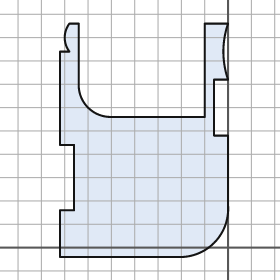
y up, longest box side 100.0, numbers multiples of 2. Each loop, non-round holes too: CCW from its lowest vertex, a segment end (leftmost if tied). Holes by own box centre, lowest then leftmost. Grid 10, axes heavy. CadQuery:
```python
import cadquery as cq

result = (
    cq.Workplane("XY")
    .moveTo(-72.0, -4.0)
    .lineTo(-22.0, -4.0)
    .threePointArc((-6.0, 2.0), (0.0, 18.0))
    .lineTo(0.0, 48.0)
    .lineTo(-6.0, 48.0)
    .lineTo(-6.0, 72.0)
    .lineTo(0.0, 72.0)
    .threePointArc((-2.0, 84.0), (0.0, 96.0))
    .lineTo(-10.0, 96.0)
    .lineTo(-10.0, 56.0)
    .lineTo(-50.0, 56.0)
    .threePointArc((-60.0, 60.0), (-64.0, 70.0))
    .lineTo(-64.0, 96.0)
    .lineTo(-68.0, 96.0)
    .threePointArc((-70.0, 90.0), (-68.0, 84.0))
    .lineTo(-72.0, 84.0)
    .lineTo(-72.0, 44.0)
    .lineTo(-66.0, 44.0)
    .lineTo(-66.0, 16.0)
    .lineTo(-72.0, 16.0)
    .close()
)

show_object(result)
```